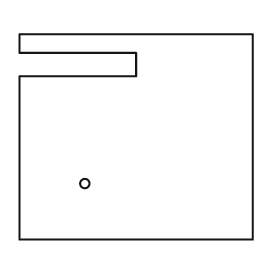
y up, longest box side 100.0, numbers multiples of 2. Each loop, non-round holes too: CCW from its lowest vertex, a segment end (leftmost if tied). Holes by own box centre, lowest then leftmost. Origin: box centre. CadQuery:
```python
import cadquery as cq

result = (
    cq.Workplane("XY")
    .moveTo(-50.0, -44.0)
    .lineTo(50.0, -44.0)
    .lineTo(50.0, 44.0)
    .lineTo(-50.0, 44.0)
    .lineTo(-50.0, 36.0)
    .lineTo(0.0, 36.0)
    .lineTo(0.0, 26.0)
    .lineTo(-50.0, 26.0)
    .close()
    .moveTo(-22.0, -20.0)
    .circle(2.0)
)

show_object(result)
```